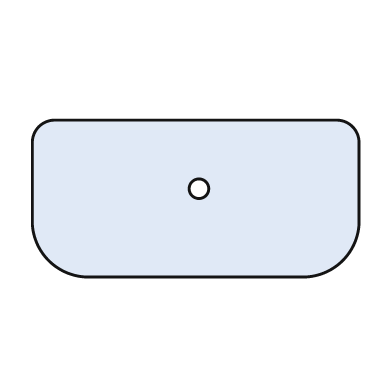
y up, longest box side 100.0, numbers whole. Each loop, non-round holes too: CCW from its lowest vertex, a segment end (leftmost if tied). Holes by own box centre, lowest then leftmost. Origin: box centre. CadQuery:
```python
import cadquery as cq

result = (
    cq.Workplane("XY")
    .moveTo(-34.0, -24.0)
    .lineTo(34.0, -24.0)
    .threePointArc((45.0, -19.0), (50.0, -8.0))
    .lineTo(50.0, 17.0)
    .threePointArc((48.0, 22.0), (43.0, 24.0))
    .lineTo(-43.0, 24.0)
    .threePointArc((-48.0, 22.0), (-50.0, 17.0))
    .lineTo(-50.0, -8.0)
    .threePointArc((-45.0, -19.0), (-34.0, -24.0))
    .close()
    .moveTo(1.0, 3.0)
    .circle(3.0)
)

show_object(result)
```